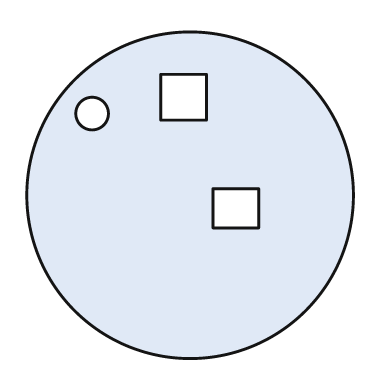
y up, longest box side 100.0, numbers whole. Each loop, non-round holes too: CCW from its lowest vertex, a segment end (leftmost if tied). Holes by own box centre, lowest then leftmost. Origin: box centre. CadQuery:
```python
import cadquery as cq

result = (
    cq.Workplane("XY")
    .moveTo(0.0, 0.0)
    .circle(50.0)
    .moveTo(7.0, -10.0)
    .lineTo(21.0, -10.0)
    .lineTo(21.0, 2.0)
    .lineTo(7.0, 2.0)
    .close()
    .moveTo(-30.0, 25.0)
    .circle(5.0)
    .moveTo(-9.0, 23.0)
    .lineTo(5.0, 23.0)
    .lineTo(5.0, 37.0)
    .lineTo(-9.0, 37.0)
    .close()
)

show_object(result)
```